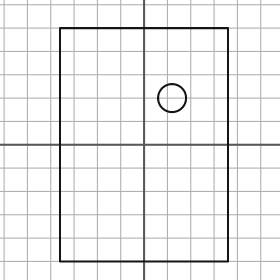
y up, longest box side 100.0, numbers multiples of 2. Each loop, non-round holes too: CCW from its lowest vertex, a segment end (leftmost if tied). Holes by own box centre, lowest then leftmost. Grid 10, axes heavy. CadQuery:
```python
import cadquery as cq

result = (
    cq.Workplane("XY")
    .moveTo(-36.0, -50.0)
    .lineTo(36.0, -50.0)
    .lineTo(36.0, 50.0)
    .lineTo(-36.0, 50.0)
    .close()
    .moveTo(12.0, 20.0)
    .circle(6.0)
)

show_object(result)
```